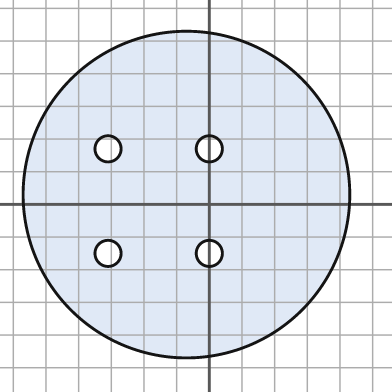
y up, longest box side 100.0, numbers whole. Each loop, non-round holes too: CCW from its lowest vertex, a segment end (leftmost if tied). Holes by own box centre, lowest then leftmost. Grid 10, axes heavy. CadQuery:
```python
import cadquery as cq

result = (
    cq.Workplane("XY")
    .moveTo(-7.0, 3.0)
    .circle(50.0)
    .moveTo(-31.0, -15.0)
    .circle(4.0)
    .moveTo(0.0, -15.0)
    .circle(4.0)
    .moveTo(-31.0, 17.0)
    .circle(4.0)
    .moveTo(0.0, 17.0)
    .circle(4.0)
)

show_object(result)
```